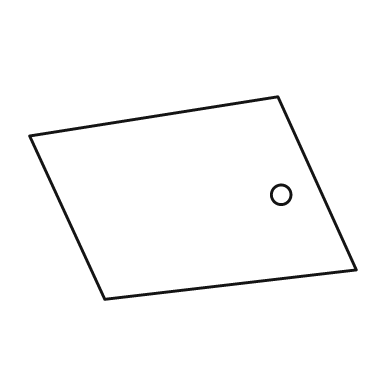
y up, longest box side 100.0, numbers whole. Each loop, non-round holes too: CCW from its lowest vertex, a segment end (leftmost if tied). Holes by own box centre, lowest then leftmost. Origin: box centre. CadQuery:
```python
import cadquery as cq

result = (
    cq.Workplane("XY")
    .moveTo(-27.0, -31.0)
    .lineTo(50.0, -22.0)
    .lineTo(26.0, 31.0)
    .lineTo(-50.0, 19.0)
    .close()
    .moveTo(27.0, 1.0)
    .circle(3.0)
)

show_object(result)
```